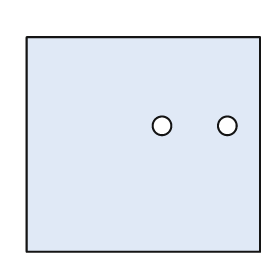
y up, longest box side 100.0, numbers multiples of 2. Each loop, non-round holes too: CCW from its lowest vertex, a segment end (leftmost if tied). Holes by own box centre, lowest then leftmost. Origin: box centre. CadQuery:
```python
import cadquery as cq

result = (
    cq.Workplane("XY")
    .moveTo(-50.0, -46.0)
    .lineTo(50.0, -46.0)
    .lineTo(50.0, 46.0)
    .lineTo(-50.0, 46.0)
    .close()
    .moveTo(8.0, 8.0)
    .circle(4.0)
    .moveTo(36.0, 8.0)
    .circle(4.0)
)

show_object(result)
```